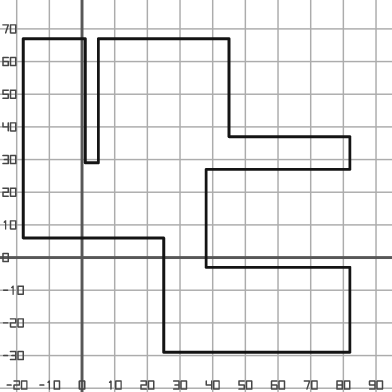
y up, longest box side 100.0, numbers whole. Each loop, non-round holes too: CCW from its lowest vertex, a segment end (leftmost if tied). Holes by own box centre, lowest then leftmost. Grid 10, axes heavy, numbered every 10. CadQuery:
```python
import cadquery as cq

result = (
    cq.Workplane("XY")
    .moveTo(25.0, -29.0)
    .lineTo(82.0, -29.0)
    .lineTo(82.0, -3.0)
    .lineTo(38.0, -3.0)
    .lineTo(38.0, 27.0)
    .lineTo(82.0, 27.0)
    .lineTo(82.0, 37.0)
    .lineTo(45.0, 37.0)
    .lineTo(45.0, 67.0)
    .lineTo(5.0, 67.0)
    .lineTo(5.0, 29.0)
    .lineTo(1.0, 29.0)
    .lineTo(1.0, 67.0)
    .lineTo(-18.0, 67.0)
    .lineTo(-18.0, 6.0)
    .lineTo(25.0, 6.0)
    .close()
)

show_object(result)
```